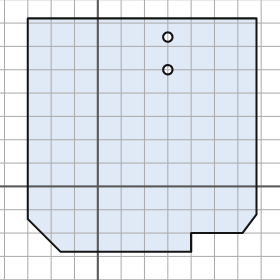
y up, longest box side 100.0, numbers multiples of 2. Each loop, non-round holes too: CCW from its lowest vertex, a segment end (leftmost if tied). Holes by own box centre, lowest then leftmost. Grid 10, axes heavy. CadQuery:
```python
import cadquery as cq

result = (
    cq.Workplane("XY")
    .moveTo(-16.0, -28.0)
    .lineTo(40.0, -28.0)
    .lineTo(40.0, -20.0)
    .lineTo(62.0, -20.0)
    .lineTo(68.0, -12.0)
    .lineTo(68.0, 72.0)
    .lineTo(-30.0, 72.0)
    .lineTo(-30.0, -14.0)
    .close()
    .moveTo(30.0, 50.0)
    .circle(2.0)
    .moveTo(30.0, 64.0)
    .circle(2.0)
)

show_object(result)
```